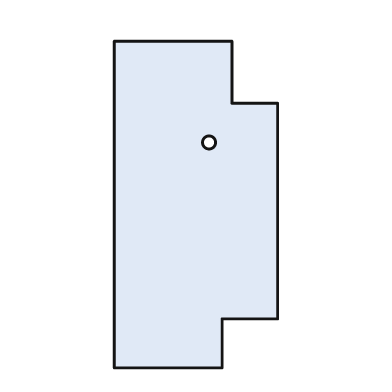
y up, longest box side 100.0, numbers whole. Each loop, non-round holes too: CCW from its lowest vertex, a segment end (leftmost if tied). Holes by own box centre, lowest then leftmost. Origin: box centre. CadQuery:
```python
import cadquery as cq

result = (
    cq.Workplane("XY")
    .moveTo(-25.0, -50.0)
    .lineTo(8.0, -50.0)
    .lineTo(8.0, -35.0)
    .lineTo(25.0, -35.0)
    .lineTo(25.0, 31.0)
    .lineTo(11.0, 31.0)
    .lineTo(11.0, 50.0)
    .lineTo(-25.0, 50.0)
    .close()
    .moveTo(4.0, 19.0)
    .circle(2.0)
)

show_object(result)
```